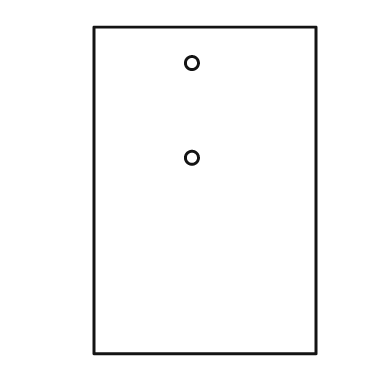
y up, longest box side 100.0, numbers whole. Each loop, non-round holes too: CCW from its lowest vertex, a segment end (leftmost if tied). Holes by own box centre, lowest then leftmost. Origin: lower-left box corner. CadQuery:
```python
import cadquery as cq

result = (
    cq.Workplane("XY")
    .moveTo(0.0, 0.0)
    .lineTo(68.0, 0.0)
    .lineTo(68.0, 100.0)
    .lineTo(0.0, 100.0)
    .close()
    .moveTo(30.0, 60.0)
    .circle(2.0)
    .moveTo(30.0, 89.0)
    .circle(2.0)
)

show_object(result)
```